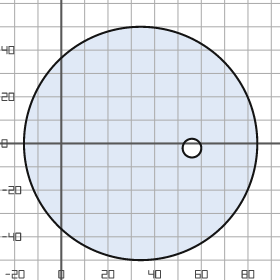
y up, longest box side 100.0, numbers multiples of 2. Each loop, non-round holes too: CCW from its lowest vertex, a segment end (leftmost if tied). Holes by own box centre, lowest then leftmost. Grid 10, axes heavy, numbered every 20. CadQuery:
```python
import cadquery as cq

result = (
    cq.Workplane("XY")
    .moveTo(34.0, 0.0)
    .circle(50.0)
    .moveTo(56.0, -2.0)
    .circle(4.0)
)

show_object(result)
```